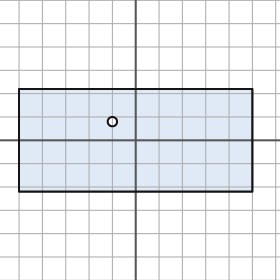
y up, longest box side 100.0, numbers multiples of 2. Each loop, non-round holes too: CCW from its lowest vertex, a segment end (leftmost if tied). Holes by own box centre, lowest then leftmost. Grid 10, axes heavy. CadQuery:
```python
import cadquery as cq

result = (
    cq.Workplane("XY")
    .moveTo(-50.0, -22.0)
    .lineTo(50.0, -22.0)
    .lineTo(50.0, 22.0)
    .lineTo(-50.0, 22.0)
    .close()
    .moveTo(-10.0, 8.0)
    .circle(2.0)
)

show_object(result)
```